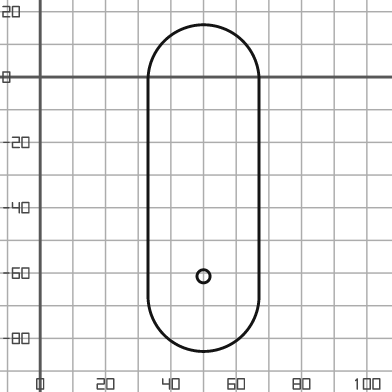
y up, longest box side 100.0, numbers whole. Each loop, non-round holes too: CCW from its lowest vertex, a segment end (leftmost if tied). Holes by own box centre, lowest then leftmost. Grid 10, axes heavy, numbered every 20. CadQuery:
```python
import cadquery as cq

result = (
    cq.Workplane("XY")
    .moveTo(33.0, -67.0)
    .threePointArc((50.0, -84.0), (67.0, -67.0))
    .lineTo(67.0, -1.0)
    .threePointArc((50.0, 16.0), (33.0, -1.0))
    .close()
    .moveTo(50.0, -61.0)
    .circle(2.0)
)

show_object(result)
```